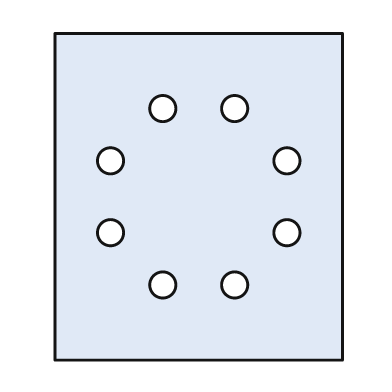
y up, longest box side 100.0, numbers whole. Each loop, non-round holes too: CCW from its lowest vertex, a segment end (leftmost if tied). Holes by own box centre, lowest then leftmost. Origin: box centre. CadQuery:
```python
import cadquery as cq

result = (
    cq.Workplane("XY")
    .moveTo(-44.0, -50.0)
    .lineTo(44.0, -50.0)
    .lineTo(44.0, 50.0)
    .lineTo(-44.0, 50.0)
    .close()
    .moveTo(-11.0, -27.0)
    .circle(4.0)
    .moveTo(11.0, -27.0)
    .circle(4.0)
    .moveTo(-27.0, -11.0)
    .circle(4.0)
    .moveTo(27.0, -11.0)
    .circle(4.0)
    .moveTo(-27.0, 11.0)
    .circle(4.0)
    .moveTo(27.0, 11.0)
    .circle(4.0)
    .moveTo(-11.0, 27.0)
    .circle(4.0)
    .moveTo(11.0, 27.0)
    .circle(4.0)
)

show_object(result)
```